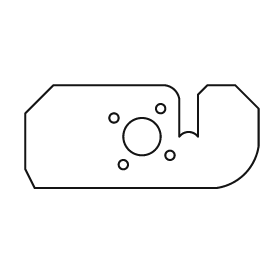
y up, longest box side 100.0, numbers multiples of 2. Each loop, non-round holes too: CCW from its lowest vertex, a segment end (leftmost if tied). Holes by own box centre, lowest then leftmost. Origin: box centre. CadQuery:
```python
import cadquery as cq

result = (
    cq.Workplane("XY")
    .moveTo(-46.0, -22.0)
    .lineTo(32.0, -22.0)
    .threePointArc((44.0, -16.0), (50.0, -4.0))
    .lineTo(50.0, 12.0)
    .lineTo(40.0, 22.0)
    .lineTo(28.0, 22.0)
    .lineTo(24.0, 18.0)
    .lineTo(24.0, 0.0)
    .threePointArc((20.0, 2.0), (16.0, 0.0))
    .lineTo(16.0, 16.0)
    .threePointArc((14.0, 20.0), (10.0, 22.0))
    .lineTo(-38.0, 22.0)
    .lineTo(-50.0, 10.0)
    .lineTo(-50.0, -14.0)
    .close()
    .moveTo(-8.0, -12.0)
    .circle(2.0)
    .moveTo(12.0, -8.0)
    .circle(2.0)
    .moveTo(0.0, 0.0)
    .circle(8.0)
    .moveTo(-12.0, 8.0)
    .circle(2.0)
    .moveTo(8.0, 12.0)
    .circle(2.0)
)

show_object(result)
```